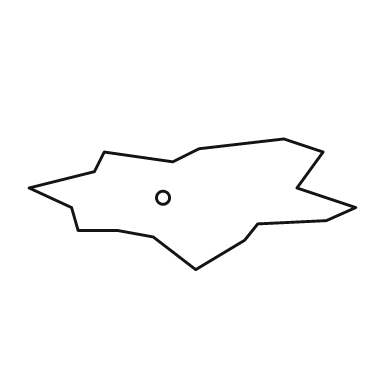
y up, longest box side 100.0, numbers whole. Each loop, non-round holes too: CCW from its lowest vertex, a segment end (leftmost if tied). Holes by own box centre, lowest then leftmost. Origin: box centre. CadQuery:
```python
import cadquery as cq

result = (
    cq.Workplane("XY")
    .moveTo(1.0, -20.0)
    .lineTo(16.0, -11.0)
    .lineTo(20.0, -6.0)
    .lineTo(41.0, -5.0)
    .lineTo(50.0, -1.0)
    .lineTo(32.0, 5.0)
    .lineTo(40.0, 16.0)
    .lineTo(28.0, 20.0)
    .lineTo(2.0, 17.0)
    .lineTo(-6.0, 13.0)
    .lineTo(-27.0, 16.0)
    .lineTo(-30.0, 10.0)
    .lineTo(-50.0, 5.0)
    .lineTo(-37.0, -1.0)
    .lineTo(-35.0, -8.0)
    .lineTo(-23.0, -8.0)
    .lineTo(-12.0, -10.0)
    .close()
    .moveTo(-9.0, 2.0)
    .circle(2.0)
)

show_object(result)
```